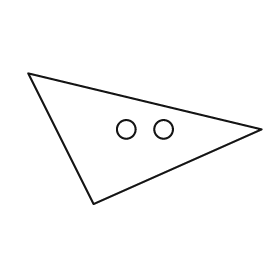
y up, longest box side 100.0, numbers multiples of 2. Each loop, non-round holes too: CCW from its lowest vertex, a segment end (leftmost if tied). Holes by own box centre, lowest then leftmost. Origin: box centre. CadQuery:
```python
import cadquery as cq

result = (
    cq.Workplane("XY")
    .moveTo(-22.0, -28.0)
    .lineTo(50.0, 4.0)
    .lineTo(-50.0, 28.0)
    .close()
    .moveTo(-8.0, 4.0)
    .circle(4.0)
    .moveTo(8.0, 4.0)
    .circle(4.0)
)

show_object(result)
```